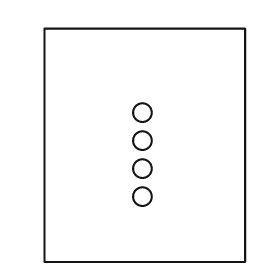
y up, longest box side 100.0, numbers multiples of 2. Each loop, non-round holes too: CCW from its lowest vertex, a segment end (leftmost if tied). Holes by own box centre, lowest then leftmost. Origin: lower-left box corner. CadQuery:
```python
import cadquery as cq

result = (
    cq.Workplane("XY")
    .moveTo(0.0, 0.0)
    .lineTo(86.0, 0.0)
    .lineTo(86.0, 100.0)
    .lineTo(0.0, 100.0)
    .close()
    .moveTo(42.0, 28.0)
    .circle(4.0)
    .moveTo(42.0, 40.0)
    .circle(4.0)
    .moveTo(42.0, 52.0)
    .circle(4.0)
    .moveTo(42.0, 64.0)
    .circle(4.0)
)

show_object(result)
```